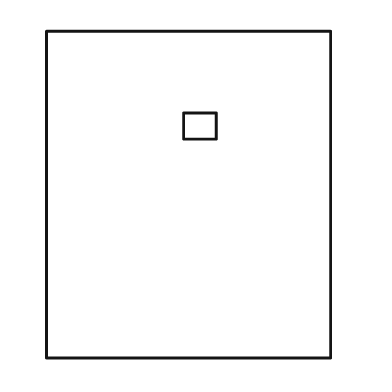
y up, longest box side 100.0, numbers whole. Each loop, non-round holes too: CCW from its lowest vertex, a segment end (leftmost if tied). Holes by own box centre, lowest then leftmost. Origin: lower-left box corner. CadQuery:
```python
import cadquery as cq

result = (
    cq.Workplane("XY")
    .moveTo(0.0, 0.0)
    .lineTo(87.0, 0.0)
    .lineTo(87.0, 100.0)
    .lineTo(0.0, 100.0)
    .close()
    .moveTo(42.0, 67.0)
    .lineTo(52.0, 67.0)
    .lineTo(52.0, 75.0)
    .lineTo(42.0, 75.0)
    .close()
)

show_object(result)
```